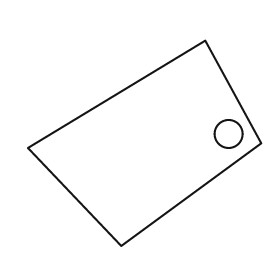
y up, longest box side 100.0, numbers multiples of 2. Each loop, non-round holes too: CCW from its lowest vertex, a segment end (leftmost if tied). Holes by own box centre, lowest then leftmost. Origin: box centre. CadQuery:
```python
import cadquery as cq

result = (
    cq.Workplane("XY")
    .moveTo(-10.0, -44.0)
    .lineTo(50.0, 0.0)
    .lineTo(26.0, 44.0)
    .lineTo(-50.0, -2.0)
    .close()
    .moveTo(36.0, 4.0)
    .circle(6.0)
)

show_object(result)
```